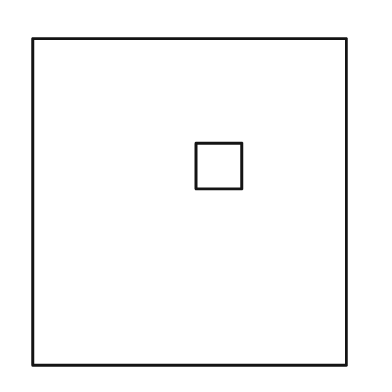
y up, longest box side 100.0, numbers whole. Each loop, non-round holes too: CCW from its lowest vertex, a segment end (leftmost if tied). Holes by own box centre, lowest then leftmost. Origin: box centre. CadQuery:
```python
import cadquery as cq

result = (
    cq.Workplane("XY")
    .moveTo(-48.0, -50.0)
    .lineTo(48.0, -50.0)
    .lineTo(48.0, 50.0)
    .lineTo(-48.0, 50.0)
    .close()
    .moveTo(2.0, 4.0)
    .lineTo(16.0, 4.0)
    .lineTo(16.0, 18.0)
    .lineTo(2.0, 18.0)
    .close()
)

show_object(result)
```